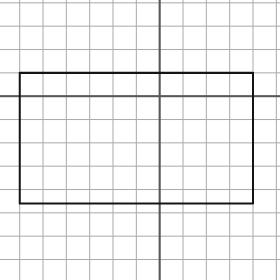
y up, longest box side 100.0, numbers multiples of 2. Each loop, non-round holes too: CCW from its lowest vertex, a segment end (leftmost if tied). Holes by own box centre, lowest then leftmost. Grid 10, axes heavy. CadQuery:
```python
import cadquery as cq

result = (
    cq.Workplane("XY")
    .moveTo(-60.0, -46.0)
    .lineTo(40.0, -46.0)
    .lineTo(40.0, 10.0)
    .lineTo(-60.0, 10.0)
    .close()
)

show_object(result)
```